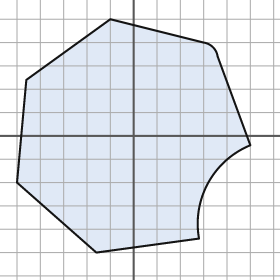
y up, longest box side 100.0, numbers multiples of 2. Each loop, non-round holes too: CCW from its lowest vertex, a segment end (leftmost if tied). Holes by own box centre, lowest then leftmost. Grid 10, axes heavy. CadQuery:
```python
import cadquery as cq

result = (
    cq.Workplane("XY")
    .moveTo(-16.0, -50.0)
    .lineTo(28.0, -44.0)
    .threePointArc((32.0, -20.0), (50.0, -4.0))
    .lineTo(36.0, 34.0)
    .threePointArc((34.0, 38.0), (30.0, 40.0))
    .lineTo(-10.0, 50.0)
    .lineTo(-46.0, 24.0)
    .lineTo(-50.0, -20.0)
    .close()
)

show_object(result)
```